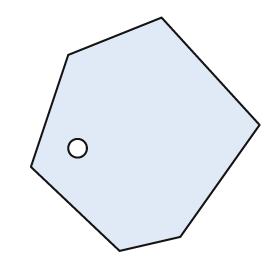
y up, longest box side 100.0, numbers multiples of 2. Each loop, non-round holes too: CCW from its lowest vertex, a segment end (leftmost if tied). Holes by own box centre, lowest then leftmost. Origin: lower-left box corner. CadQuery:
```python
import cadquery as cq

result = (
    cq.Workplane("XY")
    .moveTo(38.0, 0.0)
    .lineTo(64.0, 6.0)
    .lineTo(98.0, 54.0)
    .lineTo(56.0, 100.0)
    .lineTo(16.0, 84.0)
    .lineTo(0.0, 36.0)
    .close()
    .moveTo(20.0, 44.0)
    .circle(4.0)
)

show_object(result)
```